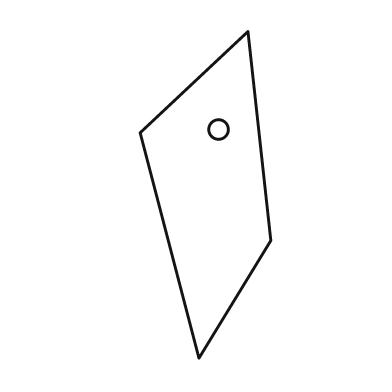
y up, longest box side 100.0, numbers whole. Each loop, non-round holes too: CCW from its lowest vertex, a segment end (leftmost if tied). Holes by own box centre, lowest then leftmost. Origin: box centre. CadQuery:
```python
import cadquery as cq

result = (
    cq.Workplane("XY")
    .moveTo(-2.0, -50.0)
    .lineTo(20.0, -14.0)
    .lineTo(13.0, 50.0)
    .lineTo(-20.0, 19.0)
    .close()
    .moveTo(4.0, 20.0)
    .circle(3.0)
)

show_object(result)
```